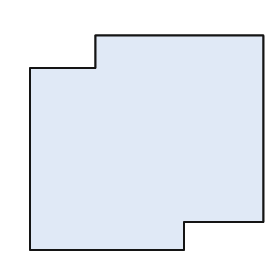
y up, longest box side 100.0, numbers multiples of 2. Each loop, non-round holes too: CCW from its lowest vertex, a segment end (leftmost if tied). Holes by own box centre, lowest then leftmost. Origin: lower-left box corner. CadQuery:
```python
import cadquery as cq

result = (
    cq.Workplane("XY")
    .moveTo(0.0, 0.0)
    .lineTo(66.0, 0.0)
    .lineTo(66.0, 12.0)
    .lineTo(100.0, 12.0)
    .lineTo(100.0, 92.0)
    .lineTo(28.0, 92.0)
    .lineTo(28.0, 78.0)
    .lineTo(0.0, 78.0)
    .close()
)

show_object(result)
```